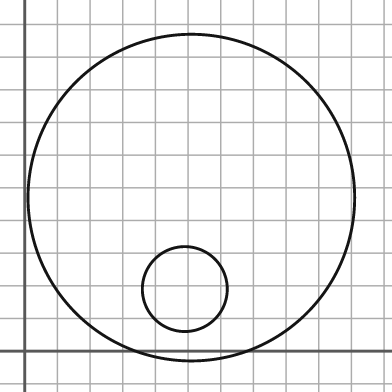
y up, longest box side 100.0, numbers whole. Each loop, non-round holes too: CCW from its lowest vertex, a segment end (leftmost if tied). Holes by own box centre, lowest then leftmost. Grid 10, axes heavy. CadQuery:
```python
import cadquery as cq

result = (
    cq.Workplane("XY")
    .moveTo(51.0, 47.0)
    .circle(50.0)
    .moveTo(49.0, 19.0)
    .circle(13.0)
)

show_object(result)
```